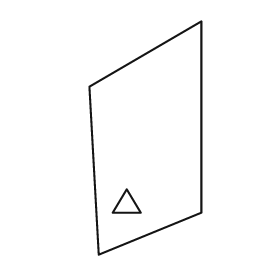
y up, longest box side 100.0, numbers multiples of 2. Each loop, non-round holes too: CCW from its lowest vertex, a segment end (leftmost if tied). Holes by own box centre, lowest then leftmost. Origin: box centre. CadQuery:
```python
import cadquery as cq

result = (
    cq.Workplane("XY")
    .moveTo(-20.0, -50.0)
    .lineTo(24.0, -32.0)
    .lineTo(24.0, 50.0)
    .lineTo(-24.0, 22.0)
    .close()
    .moveTo(-14.0, -32.0)
    .lineTo(-2.0, -32.0)
    .lineTo(-8.0, -22.0)
    .close()
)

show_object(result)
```